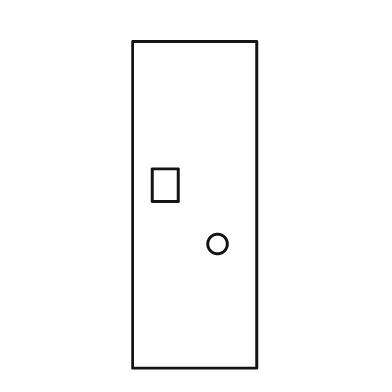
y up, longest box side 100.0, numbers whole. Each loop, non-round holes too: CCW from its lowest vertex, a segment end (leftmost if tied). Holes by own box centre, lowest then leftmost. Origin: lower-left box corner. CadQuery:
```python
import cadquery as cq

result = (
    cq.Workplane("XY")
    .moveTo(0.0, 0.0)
    .lineTo(38.0, 0.0)
    .lineTo(38.0, 100.0)
    .lineTo(0.0, 100.0)
    .close()
    .moveTo(26.0, 38.0)
    .circle(3.0)
    .moveTo(6.0, 51.0)
    .lineTo(14.0, 51.0)
    .lineTo(14.0, 61.0)
    .lineTo(6.0, 61.0)
    .close()
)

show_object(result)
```